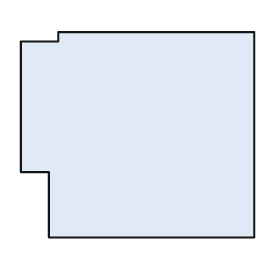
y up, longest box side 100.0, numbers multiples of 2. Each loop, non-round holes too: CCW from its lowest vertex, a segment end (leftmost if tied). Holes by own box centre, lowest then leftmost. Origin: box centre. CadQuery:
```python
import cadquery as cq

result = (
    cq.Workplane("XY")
    .moveTo(-38.0, -44.0)
    .lineTo(50.0, -44.0)
    .lineTo(50.0, 44.0)
    .lineTo(-34.0, 44.0)
    .lineTo(-34.0, 40.0)
    .lineTo(-50.0, 40.0)
    .lineTo(-50.0, -16.0)
    .lineTo(-38.0, -16.0)
    .close()
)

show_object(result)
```